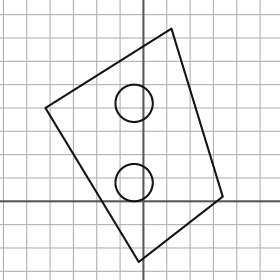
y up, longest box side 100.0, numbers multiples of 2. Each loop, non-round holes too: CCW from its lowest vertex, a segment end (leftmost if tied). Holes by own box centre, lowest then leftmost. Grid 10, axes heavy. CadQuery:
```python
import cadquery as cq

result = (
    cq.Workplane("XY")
    .moveTo(-2.0, -26.0)
    .lineTo(34.0, 2.0)
    .lineTo(12.0, 74.0)
    .lineTo(-42.0, 40.0)
    .close()
    .moveTo(-4.0, 8.0)
    .circle(8.0)
    .moveTo(-4.0, 42.0)
    .circle(8.0)
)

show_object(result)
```